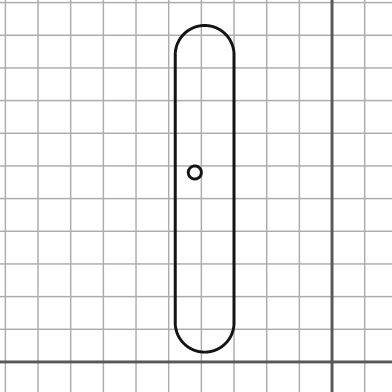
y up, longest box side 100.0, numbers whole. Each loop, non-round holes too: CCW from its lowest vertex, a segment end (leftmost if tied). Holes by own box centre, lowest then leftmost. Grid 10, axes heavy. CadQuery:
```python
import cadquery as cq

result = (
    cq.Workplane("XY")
    .moveTo(-48.0, 12.0)
    .threePointArc((-39.0, 3.0), (-30.0, 12.0))
    .lineTo(-30.0, 94.0)
    .threePointArc((-39.0, 103.0), (-48.0, 94.0))
    .close()
    .moveTo(-42.0, 58.0)
    .circle(2.0)
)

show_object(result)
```